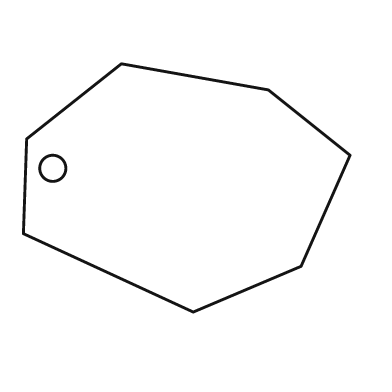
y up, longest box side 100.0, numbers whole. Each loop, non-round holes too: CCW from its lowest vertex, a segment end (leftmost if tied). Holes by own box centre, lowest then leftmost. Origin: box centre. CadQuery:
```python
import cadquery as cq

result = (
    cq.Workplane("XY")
    .moveTo(2.0, -38.0)
    .lineTo(35.0, -24.0)
    .lineTo(50.0, 10.0)
    .lineTo(25.0, 30.0)
    .lineTo(-20.0, 38.0)
    .lineTo(-49.0, 15.0)
    .lineTo(-50.0, -14.0)
    .close()
    .moveTo(-41.0, 6.0)
    .circle(4.0)
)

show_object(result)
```